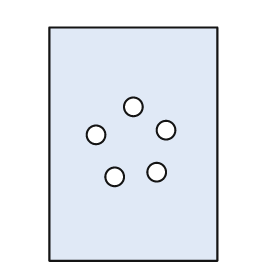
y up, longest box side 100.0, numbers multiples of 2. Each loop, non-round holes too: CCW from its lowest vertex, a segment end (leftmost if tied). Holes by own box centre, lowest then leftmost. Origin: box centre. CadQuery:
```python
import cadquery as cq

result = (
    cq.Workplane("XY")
    .moveTo(-36.0, -50.0)
    .lineTo(36.0, -50.0)
    .lineTo(36.0, 50.0)
    .lineTo(-36.0, 50.0)
    .close()
    .moveTo(-8.0, -14.0)
    .circle(4.0)
    .moveTo(10.0, -12.0)
    .circle(4.0)
    .moveTo(-16.0, 4.0)
    .circle(4.0)
    .moveTo(14.0, 6.0)
    .circle(4.0)
    .moveTo(0.0, 16.0)
    .circle(4.0)
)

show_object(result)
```